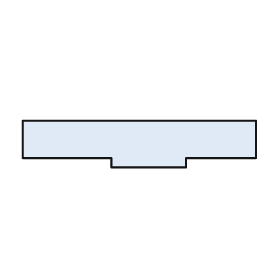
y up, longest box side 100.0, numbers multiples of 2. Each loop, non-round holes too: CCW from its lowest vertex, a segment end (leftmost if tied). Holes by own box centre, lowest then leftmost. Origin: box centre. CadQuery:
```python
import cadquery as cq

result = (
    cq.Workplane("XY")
    .moveTo(-12.0, -10.0)
    .lineTo(20.0, -10.0)
    .lineTo(20.0, -6.0)
    .lineTo(50.0, -6.0)
    .lineTo(50.0, 10.0)
    .lineTo(-50.0, 10.0)
    .lineTo(-50.0, -6.0)
    .lineTo(-12.0, -6.0)
    .close()
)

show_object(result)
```